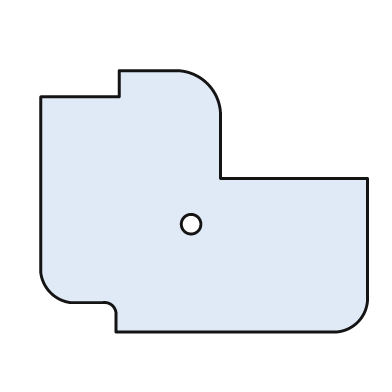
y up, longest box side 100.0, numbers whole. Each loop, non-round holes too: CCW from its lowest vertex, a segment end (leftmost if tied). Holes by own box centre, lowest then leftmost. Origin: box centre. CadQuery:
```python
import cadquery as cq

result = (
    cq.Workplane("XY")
    .moveTo(-27.0, -40.0)
    .lineTo(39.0, -40.0)
    .threePointArc((47.0, -37.0), (50.0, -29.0))
    .lineTo(50.0, 7.0)
    .lineTo(5.0, 7.0)
    .lineTo(5.0, 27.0)
    .threePointArc((1.0, 36.0), (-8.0, 40.0))
    .lineTo(-26.0, 40.0)
    .lineTo(-26.0, 32.0)
    .lineTo(-50.0, 32.0)
    .lineTo(-50.0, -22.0)
    .threePointArc((-47.0, -28.0), (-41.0, -31.0))
    .lineTo(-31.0, -31.0)
    .threePointArc((-28.0, -32.0), (-27.0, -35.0))
    .close()
    .moveTo(-4.0, -7.0)
    .circle(3.0)
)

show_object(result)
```